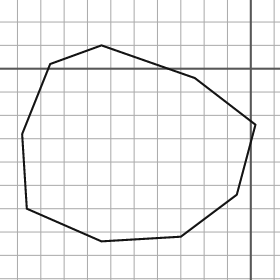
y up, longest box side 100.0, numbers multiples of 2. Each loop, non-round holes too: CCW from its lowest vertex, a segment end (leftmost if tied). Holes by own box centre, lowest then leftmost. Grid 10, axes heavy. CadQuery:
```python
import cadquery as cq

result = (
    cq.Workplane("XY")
    .moveTo(-64.0, -74.0)
    .lineTo(-30.0, -72.0)
    .lineTo(-6.0, -54.0)
    .lineTo(2.0, -24.0)
    .lineTo(-24.0, -4.0)
    .lineTo(-64.0, 10.0)
    .lineTo(-86.0, 2.0)
    .lineTo(-98.0, -28.0)
    .lineTo(-96.0, -60.0)
    .close()
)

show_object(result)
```